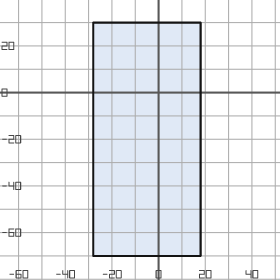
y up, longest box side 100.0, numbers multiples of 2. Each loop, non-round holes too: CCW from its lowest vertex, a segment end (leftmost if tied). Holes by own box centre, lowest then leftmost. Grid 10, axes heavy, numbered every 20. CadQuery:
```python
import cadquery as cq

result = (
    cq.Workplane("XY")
    .moveTo(-28.0, -70.0)
    .lineTo(18.0, -70.0)
    .lineTo(18.0, 30.0)
    .lineTo(-28.0, 30.0)
    .close()
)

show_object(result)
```